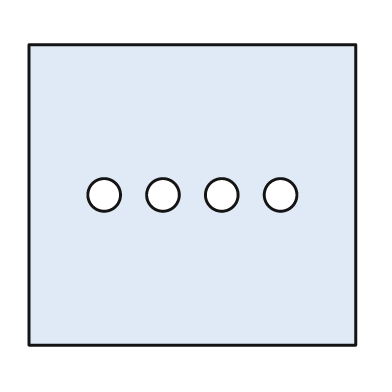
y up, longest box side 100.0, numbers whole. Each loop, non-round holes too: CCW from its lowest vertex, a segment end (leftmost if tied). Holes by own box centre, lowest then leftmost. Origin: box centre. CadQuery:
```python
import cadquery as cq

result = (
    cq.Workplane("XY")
    .moveTo(-50.0, -46.0)
    .lineTo(50.0, -46.0)
    .lineTo(50.0, 46.0)
    .lineTo(-50.0, 46.0)
    .close()
    .moveTo(-27.0, 0.0)
    .circle(5.0)
    .moveTo(-9.0, 0.0)
    .circle(5.0)
    .moveTo(9.0, 0.0)
    .circle(5.0)
    .moveTo(27.0, 0.0)
    .circle(5.0)
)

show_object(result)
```